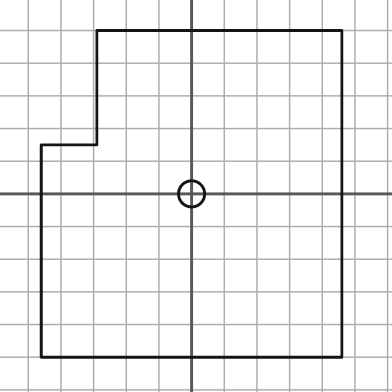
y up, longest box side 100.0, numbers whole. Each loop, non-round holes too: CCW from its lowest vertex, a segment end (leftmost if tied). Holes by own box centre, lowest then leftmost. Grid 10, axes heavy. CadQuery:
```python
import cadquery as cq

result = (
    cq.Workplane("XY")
    .moveTo(-46.0, -50.0)
    .lineTo(46.0, -50.0)
    .lineTo(46.0, 50.0)
    .lineTo(-29.0, 50.0)
    .lineTo(-29.0, 15.0)
    .lineTo(-46.0, 15.0)
    .close()
    .moveTo(0.0, 0.0)
    .circle(4.0)
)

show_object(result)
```